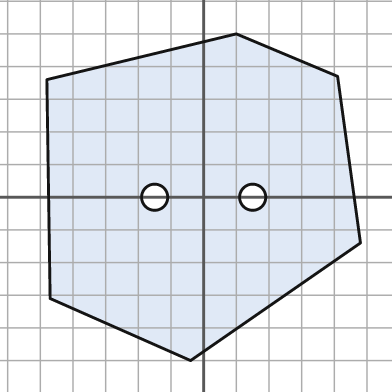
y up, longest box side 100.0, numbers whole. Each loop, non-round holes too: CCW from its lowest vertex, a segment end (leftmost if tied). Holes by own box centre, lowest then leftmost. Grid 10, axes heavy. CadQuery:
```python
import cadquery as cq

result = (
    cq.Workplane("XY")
    .moveTo(-4.0, -50.0)
    .lineTo(48.0, -14.0)
    .lineTo(41.0, 37.0)
    .lineTo(10.0, 50.0)
    .lineTo(-48.0, 36.0)
    .lineTo(-47.0, -31.0)
    .close()
    .moveTo(-15.0, 0.0)
    .circle(4.0)
    .moveTo(15.0, 0.0)
    .circle(4.0)
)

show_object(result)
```